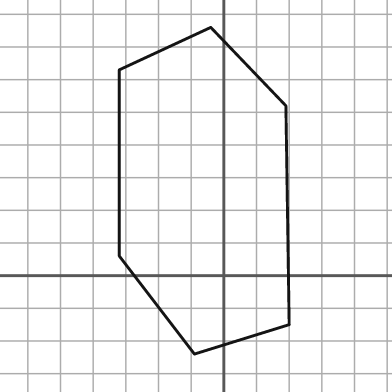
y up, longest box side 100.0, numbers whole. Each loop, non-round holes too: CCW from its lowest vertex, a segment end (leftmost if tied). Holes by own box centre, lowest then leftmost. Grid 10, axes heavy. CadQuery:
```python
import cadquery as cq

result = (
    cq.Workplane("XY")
    .moveTo(-9.0, -24.0)
    .lineTo(20.0, -15.0)
    .lineTo(19.0, 52.0)
    .lineTo(-4.0, 76.0)
    .lineTo(-32.0, 63.0)
    .lineTo(-32.0, 6.0)
    .close()
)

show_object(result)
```